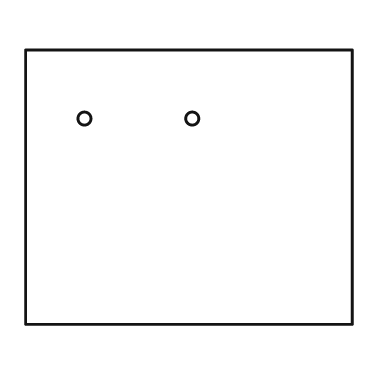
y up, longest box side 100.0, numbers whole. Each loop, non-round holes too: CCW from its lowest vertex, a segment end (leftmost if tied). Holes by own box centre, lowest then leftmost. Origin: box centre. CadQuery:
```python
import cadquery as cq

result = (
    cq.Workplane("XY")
    .moveTo(-50.0, -42.0)
    .lineTo(50.0, -42.0)
    .lineTo(50.0, 42.0)
    .lineTo(-50.0, 42.0)
    .close()
    .moveTo(-32.0, 21.0)
    .circle(2.0)
    .moveTo(1.0, 21.0)
    .circle(2.0)
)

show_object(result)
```